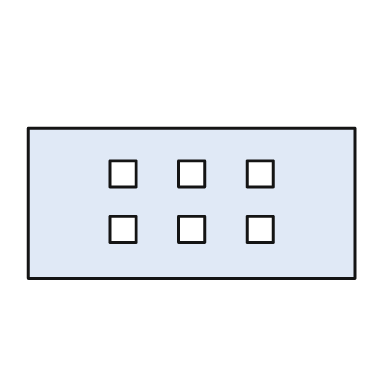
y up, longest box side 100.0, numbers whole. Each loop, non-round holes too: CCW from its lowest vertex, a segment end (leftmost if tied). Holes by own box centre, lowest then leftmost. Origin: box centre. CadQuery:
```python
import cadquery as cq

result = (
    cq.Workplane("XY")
    .moveTo(-50.0, -23.0)
    .lineTo(50.0, -23.0)
    .lineTo(50.0, 23.0)
    .lineTo(-50.0, 23.0)
    .close()
    .moveTo(-25.0, -12.0)
    .lineTo(-17.0, -12.0)
    .lineTo(-17.0, -4.0)
    .lineTo(-25.0, -4.0)
    .close()
    .moveTo(-4.0, -12.0)
    .lineTo(4.0, -12.0)
    .lineTo(4.0, -4.0)
    .lineTo(-4.0, -4.0)
    .close()
    .moveTo(17.0, -12.0)
    .lineTo(25.0, -12.0)
    .lineTo(25.0, -4.0)
    .lineTo(17.0, -4.0)
    .close()
    .moveTo(-25.0, 5.0)
    .lineTo(-17.0, 5.0)
    .lineTo(-17.0, 13.0)
    .lineTo(-25.0, 13.0)
    .close()
    .moveTo(-4.0, 5.0)
    .lineTo(4.0, 5.0)
    .lineTo(4.0, 13.0)
    .lineTo(-4.0, 13.0)
    .close()
    .moveTo(17.0, 5.0)
    .lineTo(25.0, 5.0)
    .lineTo(25.0, 13.0)
    .lineTo(17.0, 13.0)
    .close()
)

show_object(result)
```